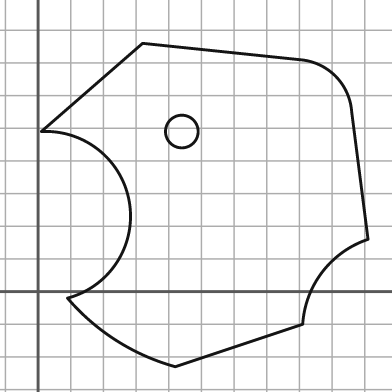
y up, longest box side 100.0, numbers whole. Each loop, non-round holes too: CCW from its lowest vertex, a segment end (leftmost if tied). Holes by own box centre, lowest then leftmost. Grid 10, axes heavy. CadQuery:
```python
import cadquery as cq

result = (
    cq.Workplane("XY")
    .moveTo(42.0, -23.0)
    .lineTo(81.0, -10.0)
    .threePointArc((87.0, 6.0), (101.0, 16.0))
    .lineTo(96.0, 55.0)
    .threePointArc((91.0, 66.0), (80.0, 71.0))
    .lineTo(32.0, 76.0)
    .lineTo(1.0, 49.0)
    .threePointArc((28.0, 27.0), (9.0, -2.0))
    .threePointArc((24.0, -15.0), (42.0, -23.0))
    .close()
    .moveTo(44.0, 49.0)
    .circle(5.0)
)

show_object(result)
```